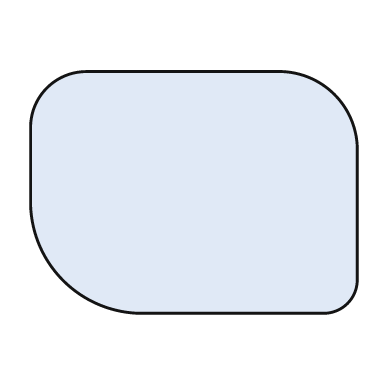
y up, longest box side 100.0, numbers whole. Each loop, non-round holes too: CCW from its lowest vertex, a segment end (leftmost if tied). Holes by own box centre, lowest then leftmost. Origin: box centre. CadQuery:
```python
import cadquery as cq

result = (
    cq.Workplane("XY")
    .moveTo(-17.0, -37.0)
    .lineTo(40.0, -37.0)
    .threePointArc((47.0, -34.0), (50.0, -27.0))
    .lineTo(50.0, 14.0)
    .threePointArc((43.0, 30.0), (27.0, 37.0))
    .lineTo(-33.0, 37.0)
    .threePointArc((-45.0, 32.0), (-50.0, 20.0))
    .lineTo(-50.0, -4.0)
    .threePointArc((-40.0, -27.0), (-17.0, -37.0))
    .close()
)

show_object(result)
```